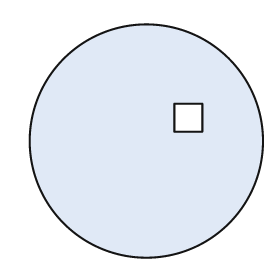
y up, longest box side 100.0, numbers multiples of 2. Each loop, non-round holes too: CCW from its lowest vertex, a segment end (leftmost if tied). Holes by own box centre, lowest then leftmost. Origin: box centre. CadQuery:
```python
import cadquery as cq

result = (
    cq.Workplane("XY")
    .moveTo(0.0, 0.0)
    .circle(50.0)
    .moveTo(12.0, 4.0)
    .lineTo(24.0, 4.0)
    .lineTo(24.0, 16.0)
    .lineTo(12.0, 16.0)
    .close()
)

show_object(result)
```